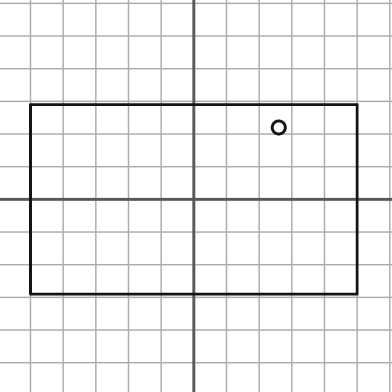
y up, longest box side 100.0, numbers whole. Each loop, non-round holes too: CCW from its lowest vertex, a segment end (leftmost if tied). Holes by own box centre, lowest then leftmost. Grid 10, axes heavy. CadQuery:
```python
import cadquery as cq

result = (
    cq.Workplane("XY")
    .moveTo(-50.0, -29.0)
    .lineTo(50.0, -29.0)
    .lineTo(50.0, 29.0)
    .lineTo(-50.0, 29.0)
    .close()
    .moveTo(26.0, 22.0)
    .circle(2.0)
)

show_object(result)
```